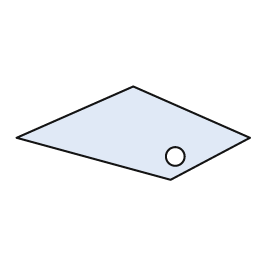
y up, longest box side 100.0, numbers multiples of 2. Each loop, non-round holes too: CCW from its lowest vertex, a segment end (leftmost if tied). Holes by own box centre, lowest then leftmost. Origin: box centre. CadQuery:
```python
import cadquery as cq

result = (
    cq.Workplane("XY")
    .moveTo(16.0, -20.0)
    .lineTo(50.0, -2.0)
    .lineTo(0.0, 20.0)
    .lineTo(-50.0, -2.0)
    .close()
    .moveTo(18.0, -10.0)
    .circle(4.0)
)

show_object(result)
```